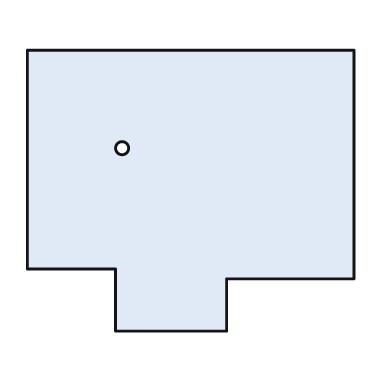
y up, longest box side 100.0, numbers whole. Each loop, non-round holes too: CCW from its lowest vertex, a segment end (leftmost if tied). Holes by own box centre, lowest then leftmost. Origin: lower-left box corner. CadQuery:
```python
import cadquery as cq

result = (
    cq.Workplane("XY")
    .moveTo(27.0, 0.0)
    .lineTo(61.0, 0.0)
    .lineTo(61.0, 16.0)
    .lineTo(100.0, 16.0)
    .lineTo(100.0, 86.0)
    .lineTo(0.0, 86.0)
    .lineTo(0.0, 19.0)
    .lineTo(27.0, 19.0)
    .close()
    .moveTo(29.0, 56.0)
    .circle(2.0)
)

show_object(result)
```